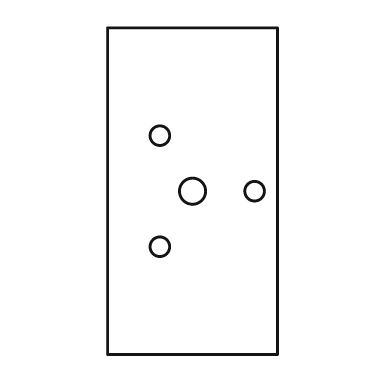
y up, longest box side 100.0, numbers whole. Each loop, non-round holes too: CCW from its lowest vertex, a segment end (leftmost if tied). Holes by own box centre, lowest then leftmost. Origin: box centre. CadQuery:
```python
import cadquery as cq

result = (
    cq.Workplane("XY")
    .moveTo(-26.0, -50.0)
    .lineTo(26.0, -50.0)
    .lineTo(26.0, 50.0)
    .lineTo(-26.0, 50.0)
    .close()
    .moveTo(-10.0, -17.0)
    .circle(3.0)
    .moveTo(0.0, 0.0)
    .circle(4.0)
    .moveTo(19.0, 0.0)
    .circle(3.0)
    .moveTo(-10.0, 17.0)
    .circle(3.0)
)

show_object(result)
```